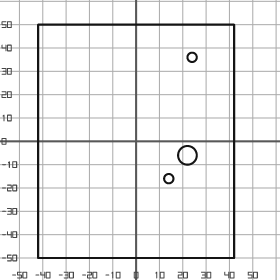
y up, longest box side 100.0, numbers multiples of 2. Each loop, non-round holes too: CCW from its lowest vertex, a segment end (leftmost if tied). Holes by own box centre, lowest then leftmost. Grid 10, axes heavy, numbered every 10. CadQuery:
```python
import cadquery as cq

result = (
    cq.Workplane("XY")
    .moveTo(-42.0, -50.0)
    .lineTo(42.0, -50.0)
    .lineTo(42.0, 50.0)
    .lineTo(-42.0, 50.0)
    .close()
    .moveTo(14.0, -16.0)
    .circle(2.0)
    .moveTo(22.0, -6.0)
    .circle(4.0)
    .moveTo(24.0, 36.0)
    .circle(2.0)
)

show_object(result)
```